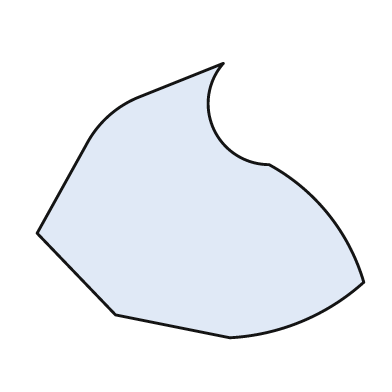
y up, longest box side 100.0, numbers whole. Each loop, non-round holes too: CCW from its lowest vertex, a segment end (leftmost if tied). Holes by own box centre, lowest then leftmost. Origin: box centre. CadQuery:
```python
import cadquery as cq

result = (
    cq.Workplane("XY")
    .moveTo(9.0, -42.0)
    .threePointArc((31.0, -37.0), (50.0, -25.0))
    .threePointArc((39.0, -4.0), (21.0, 11.0))
    .threePointArc((4.0, 22.0), (7.0, 42.0))
    .lineTo(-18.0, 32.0)
    .threePointArc((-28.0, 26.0), (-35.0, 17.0))
    .lineTo(-50.0, -10.0)
    .lineTo(-26.0, -35.0)
    .close()
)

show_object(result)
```